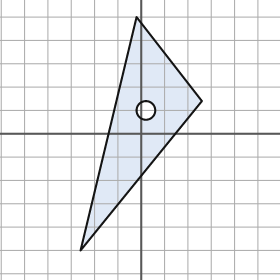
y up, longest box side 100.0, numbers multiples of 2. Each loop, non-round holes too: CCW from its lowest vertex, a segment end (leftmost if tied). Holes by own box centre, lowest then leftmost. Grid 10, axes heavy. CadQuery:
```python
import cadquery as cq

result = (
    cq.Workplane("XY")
    .moveTo(-26.0, -50.0)
    .lineTo(26.0, 14.0)
    .lineTo(-2.0, 50.0)
    .close()
    .moveTo(2.0, 10.0)
    .circle(4.0)
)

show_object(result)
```